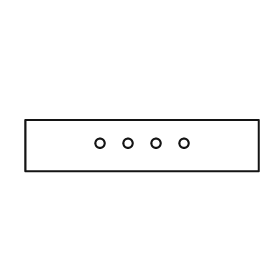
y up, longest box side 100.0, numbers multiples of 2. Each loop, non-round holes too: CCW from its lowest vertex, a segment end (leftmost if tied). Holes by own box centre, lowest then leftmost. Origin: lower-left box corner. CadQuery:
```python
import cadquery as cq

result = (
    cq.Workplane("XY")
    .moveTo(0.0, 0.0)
    .lineTo(100.0, 0.0)
    .lineTo(100.0, 22.0)
    .lineTo(0.0, 22.0)
    .close()
    .moveTo(32.0, 12.0)
    .circle(2.0)
    .moveTo(44.0, 12.0)
    .circle(2.0)
    .moveTo(56.0, 12.0)
    .circle(2.0)
    .moveTo(68.0, 12.0)
    .circle(2.0)
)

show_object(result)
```